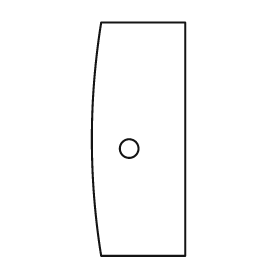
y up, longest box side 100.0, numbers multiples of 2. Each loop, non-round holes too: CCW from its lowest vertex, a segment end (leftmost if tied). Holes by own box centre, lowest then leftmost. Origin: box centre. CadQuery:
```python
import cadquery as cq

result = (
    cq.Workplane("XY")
    .moveTo(-16.0, -50.0)
    .lineTo(20.0, -50.0)
    .lineTo(20.0, 50.0)
    .lineTo(-16.0, 50.0)
    .threePointArc((-20.0, 0.0), (-16.0, -50.0))
    .close()
    .moveTo(-4.0, -4.0)
    .circle(4.0)
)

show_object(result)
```